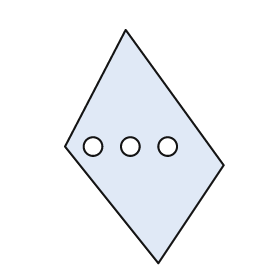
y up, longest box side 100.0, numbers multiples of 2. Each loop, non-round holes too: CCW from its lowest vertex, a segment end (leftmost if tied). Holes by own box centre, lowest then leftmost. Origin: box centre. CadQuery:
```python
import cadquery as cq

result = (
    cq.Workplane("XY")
    .moveTo(6.0, -50.0)
    .lineTo(34.0, -8.0)
    .lineTo(-8.0, 50.0)
    .lineTo(-34.0, 0.0)
    .close()
    .moveTo(-22.0, 0.0)
    .circle(4.0)
    .moveTo(-6.0, 0.0)
    .circle(4.0)
    .moveTo(10.0, 0.0)
    .circle(4.0)
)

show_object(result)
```